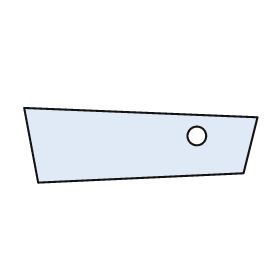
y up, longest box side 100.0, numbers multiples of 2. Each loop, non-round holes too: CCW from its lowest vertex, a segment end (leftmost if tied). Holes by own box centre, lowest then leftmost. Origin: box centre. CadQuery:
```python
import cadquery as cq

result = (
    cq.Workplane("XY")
    .moveTo(-44.0, -16.0)
    .lineTo(44.0, -12.0)
    .lineTo(50.0, 12.0)
    .lineTo(-50.0, 16.0)
    .close()
    .moveTo(24.0, 4.0)
    .circle(4.0)
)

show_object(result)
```